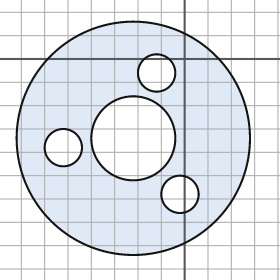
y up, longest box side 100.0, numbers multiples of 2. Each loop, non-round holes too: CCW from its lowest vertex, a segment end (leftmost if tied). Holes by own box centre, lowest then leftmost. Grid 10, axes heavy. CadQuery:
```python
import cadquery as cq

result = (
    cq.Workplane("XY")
    .moveTo(-22.0, -34.0)
    .circle(50.0)
    .moveTo(-2.0, -58.0)
    .circle(8.0)
    .moveTo(-52.0, -38.0)
    .circle(8.0)
    .moveTo(-22.0, -34.0)
    .circle(18.0)
    .moveTo(-12.0, -6.0)
    .circle(8.0)
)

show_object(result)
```